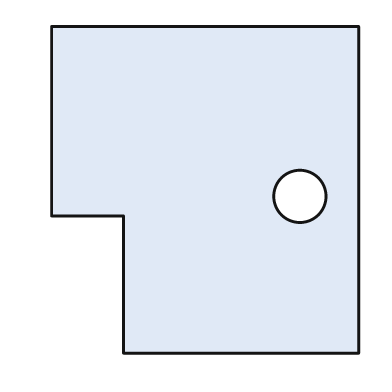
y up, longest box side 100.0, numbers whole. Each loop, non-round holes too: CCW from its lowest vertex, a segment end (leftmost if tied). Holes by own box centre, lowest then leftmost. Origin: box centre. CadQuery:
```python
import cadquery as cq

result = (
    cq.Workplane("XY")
    .moveTo(-25.0, -50.0)
    .lineTo(47.0, -50.0)
    .lineTo(47.0, 50.0)
    .lineTo(-47.0, 50.0)
    .lineTo(-47.0, -8.0)
    .lineTo(-25.0, -8.0)
    .close()
    .moveTo(29.0, -2.0)
    .circle(8.0)
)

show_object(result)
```